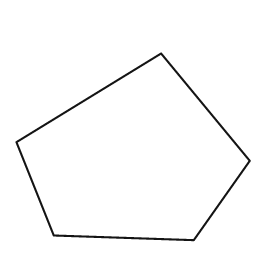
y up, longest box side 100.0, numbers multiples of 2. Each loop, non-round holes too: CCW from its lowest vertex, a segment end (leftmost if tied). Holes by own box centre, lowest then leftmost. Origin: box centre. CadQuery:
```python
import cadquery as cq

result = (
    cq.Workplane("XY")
    .moveTo(26.0, -40.0)
    .lineTo(50.0, -6.0)
    .lineTo(12.0, 40.0)
    .lineTo(-50.0, 2.0)
    .lineTo(-34.0, -38.0)
    .close()
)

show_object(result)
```